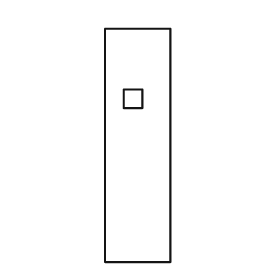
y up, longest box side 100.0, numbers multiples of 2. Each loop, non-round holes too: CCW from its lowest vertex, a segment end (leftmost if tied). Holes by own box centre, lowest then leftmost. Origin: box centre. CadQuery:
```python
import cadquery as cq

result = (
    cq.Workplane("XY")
    .moveTo(-14.0, -50.0)
    .lineTo(14.0, -50.0)
    .lineTo(14.0, 50.0)
    .lineTo(-14.0, 50.0)
    .close()
    .moveTo(-6.0, 16.0)
    .lineTo(2.0, 16.0)
    .lineTo(2.0, 24.0)
    .lineTo(-6.0, 24.0)
    .close()
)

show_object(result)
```